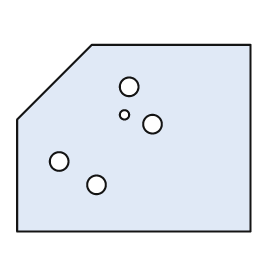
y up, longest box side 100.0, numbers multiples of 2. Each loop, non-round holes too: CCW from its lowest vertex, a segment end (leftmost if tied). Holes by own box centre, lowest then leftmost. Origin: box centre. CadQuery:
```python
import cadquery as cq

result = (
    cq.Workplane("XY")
    .moveTo(-50.0, -40.0)
    .lineTo(50.0, -40.0)
    .lineTo(50.0, 40.0)
    .lineTo(-18.0, 40.0)
    .lineTo(-50.0, 8.0)
    .close()
    .moveTo(-16.0, -20.0)
    .circle(4.0)
    .moveTo(-32.0, -10.0)
    .circle(4.0)
    .moveTo(8.0, 6.0)
    .circle(4.0)
    .moveTo(-4.0, 10.0)
    .circle(2.0)
    .moveTo(-2.0, 22.0)
    .circle(4.0)
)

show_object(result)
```